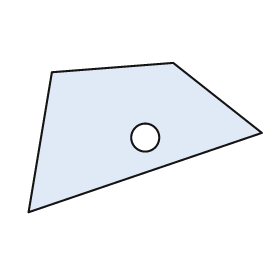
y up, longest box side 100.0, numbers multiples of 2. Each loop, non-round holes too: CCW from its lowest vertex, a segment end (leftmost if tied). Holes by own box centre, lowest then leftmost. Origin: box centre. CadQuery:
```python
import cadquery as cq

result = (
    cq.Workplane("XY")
    .moveTo(-50.0, -32.0)
    .lineTo(50.0, 2.0)
    .lineTo(12.0, 32.0)
    .lineTo(-40.0, 28.0)
    .close()
    .moveTo(0.0, 0.0)
    .circle(6.0)
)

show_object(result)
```